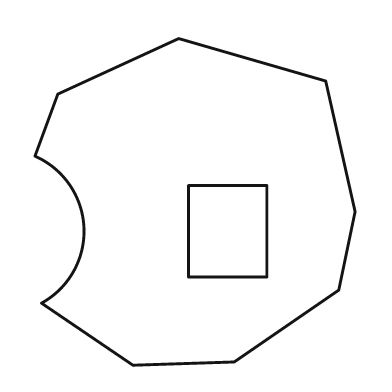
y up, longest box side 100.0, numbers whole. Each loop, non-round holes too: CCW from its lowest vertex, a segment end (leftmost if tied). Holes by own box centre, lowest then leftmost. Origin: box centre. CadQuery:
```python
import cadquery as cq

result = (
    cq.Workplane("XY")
    .moveTo(-19.0, -50.0)
    .lineTo(12.0, -49.0)
    .lineTo(44.0, -27.0)
    .lineTo(49.0, -3.0)
    .lineTo(40.0, 37.0)
    .lineTo(-5.0, 50.0)
    .lineTo(-42.0, 33.0)
    .lineTo(-49.0, 14.0)
    .threePointArc((-34.0, -8.0), (-47.0, -31.0))
    .close()
    .moveTo(-2.0, -23.0)
    .lineTo(22.0, -23.0)
    .lineTo(22.0, 5.0)
    .lineTo(-2.0, 5.0)
    .close()
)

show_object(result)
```